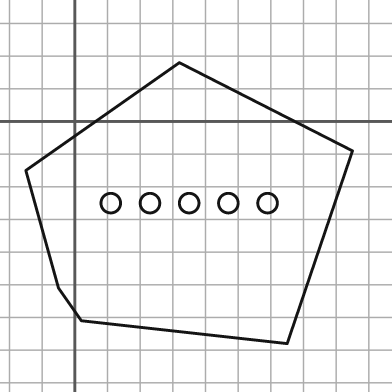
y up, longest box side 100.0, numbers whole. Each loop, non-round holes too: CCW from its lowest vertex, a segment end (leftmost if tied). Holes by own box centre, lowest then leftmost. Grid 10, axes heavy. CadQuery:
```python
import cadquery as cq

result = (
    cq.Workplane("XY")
    .moveTo(65.0, -68.0)
    .lineTo(85.0, -9.0)
    .lineTo(32.0, 18.0)
    .lineTo(-15.0, -15.0)
    .lineTo(-5.0, -51.0)
    .lineTo(2.0, -61.0)
    .close()
    .moveTo(11.0, -25.0)
    .circle(3.0)
    .moveTo(23.0, -25.0)
    .circle(3.0)
    .moveTo(35.0, -25.0)
    .circle(3.0)
    .moveTo(47.0, -25.0)
    .circle(3.0)
    .moveTo(59.0, -25.0)
    .circle(3.0)
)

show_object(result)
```